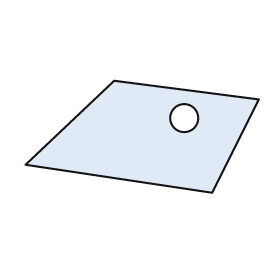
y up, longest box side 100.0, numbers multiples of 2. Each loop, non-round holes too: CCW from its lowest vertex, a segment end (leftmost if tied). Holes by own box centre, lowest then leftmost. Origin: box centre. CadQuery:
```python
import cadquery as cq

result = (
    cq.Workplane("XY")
    .moveTo(30.0, -24.0)
    .lineTo(50.0, 16.0)
    .lineTo(-12.0, 24.0)
    .lineTo(-50.0, -12.0)
    .close()
    .moveTo(18.0, 8.0)
    .circle(6.0)
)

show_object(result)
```